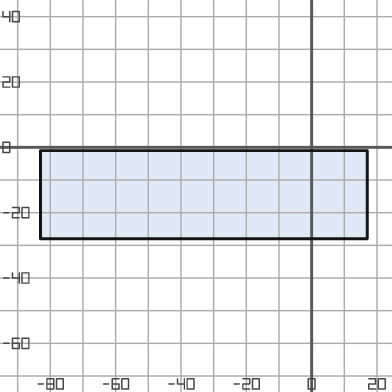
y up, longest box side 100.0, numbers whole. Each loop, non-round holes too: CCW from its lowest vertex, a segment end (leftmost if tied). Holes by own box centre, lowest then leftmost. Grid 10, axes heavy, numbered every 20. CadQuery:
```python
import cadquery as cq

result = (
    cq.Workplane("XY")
    .moveTo(-83.0, -28.0)
    .lineTo(17.0, -28.0)
    .lineTo(17.0, -1.0)
    .lineTo(-83.0, -1.0)
    .close()
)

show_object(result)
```